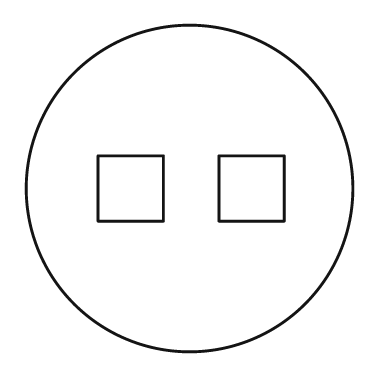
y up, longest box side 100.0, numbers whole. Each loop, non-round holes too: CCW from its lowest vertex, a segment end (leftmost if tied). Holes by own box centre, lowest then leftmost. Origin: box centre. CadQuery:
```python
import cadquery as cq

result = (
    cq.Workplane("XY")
    .moveTo(0.0, 0.0)
    .circle(50.0)
    .moveTo(-28.0, -10.0)
    .lineTo(-8.0, -10.0)
    .lineTo(-8.0, 10.0)
    .lineTo(-28.0, 10.0)
    .close()
    .moveTo(9.0, -10.0)
    .lineTo(29.0, -10.0)
    .lineTo(29.0, 10.0)
    .lineTo(9.0, 10.0)
    .close()
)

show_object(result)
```